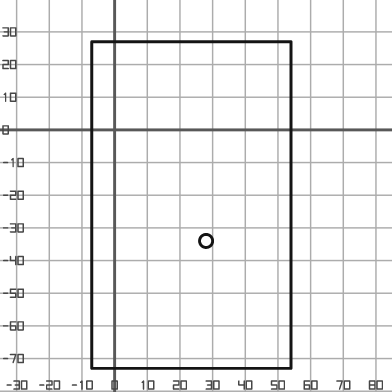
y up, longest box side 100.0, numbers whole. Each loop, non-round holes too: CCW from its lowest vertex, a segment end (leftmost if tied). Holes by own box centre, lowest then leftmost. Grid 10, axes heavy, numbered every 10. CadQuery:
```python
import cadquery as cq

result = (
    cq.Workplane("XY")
    .moveTo(-7.0, -73.0)
    .lineTo(54.0, -73.0)
    .lineTo(54.0, 27.0)
    .lineTo(-7.0, 27.0)
    .close()
    .moveTo(28.0, -34.0)
    .circle(2.0)
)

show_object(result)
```